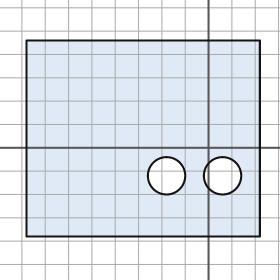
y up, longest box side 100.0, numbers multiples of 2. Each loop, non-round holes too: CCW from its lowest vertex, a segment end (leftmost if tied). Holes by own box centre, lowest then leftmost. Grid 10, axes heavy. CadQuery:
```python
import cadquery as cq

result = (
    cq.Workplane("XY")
    .moveTo(-78.0, -38.0)
    .lineTo(22.0, -38.0)
    .lineTo(22.0, 46.0)
    .lineTo(-78.0, 46.0)
    .close()
    .moveTo(-18.0, -12.0)
    .circle(8.0)
    .moveTo(6.0, -12.0)
    .circle(8.0)
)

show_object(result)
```